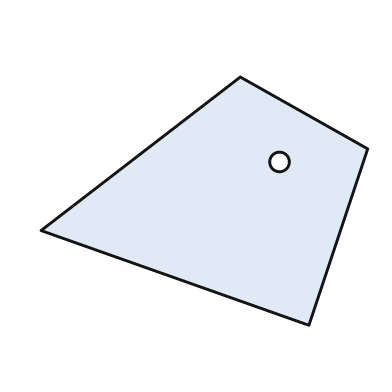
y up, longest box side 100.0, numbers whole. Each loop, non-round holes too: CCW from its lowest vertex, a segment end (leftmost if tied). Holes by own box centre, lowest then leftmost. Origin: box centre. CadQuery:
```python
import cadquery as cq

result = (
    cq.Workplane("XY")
    .moveTo(32.0, -38.0)
    .lineTo(50.0, 16.0)
    .lineTo(11.0, 38.0)
    .lineTo(-50.0, -9.0)
    .close()
    .moveTo(23.0, 12.0)
    .circle(3.0)
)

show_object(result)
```